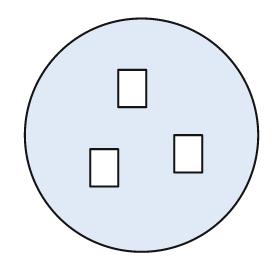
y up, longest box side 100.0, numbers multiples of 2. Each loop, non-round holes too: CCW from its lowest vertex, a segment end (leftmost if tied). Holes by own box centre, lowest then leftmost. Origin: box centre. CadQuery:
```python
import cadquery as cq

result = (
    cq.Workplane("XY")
    .moveTo(0.0, 0.0)
    .circle(50.0)
    .moveTo(-22.0, -22.0)
    .lineTo(-10.0, -22.0)
    .lineTo(-10.0, -6.0)
    .lineTo(-22.0, -6.0)
    .close()
    .moveTo(14.0, -16.0)
    .lineTo(26.0, -16.0)
    .lineTo(26.0, 0.0)
    .lineTo(14.0, 0.0)
    .close()
    .moveTo(-10.0, 12.0)
    .lineTo(2.0, 12.0)
    .lineTo(2.0, 28.0)
    .lineTo(-10.0, 28.0)
    .close()
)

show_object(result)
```